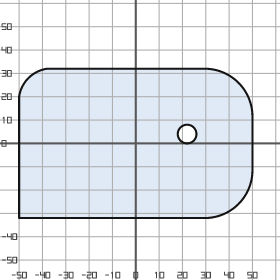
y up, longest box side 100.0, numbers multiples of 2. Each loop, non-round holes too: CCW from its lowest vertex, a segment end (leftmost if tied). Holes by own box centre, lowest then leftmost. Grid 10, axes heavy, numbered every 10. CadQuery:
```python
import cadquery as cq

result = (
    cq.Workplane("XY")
    .moveTo(-50.0, -32.0)
    .lineTo(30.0, -32.0)
    .threePointArc((44.0, -26.0), (50.0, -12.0))
    .lineTo(50.0, 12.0)
    .threePointArc((44.0, 26.0), (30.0, 32.0))
    .lineTo(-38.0, 32.0)
    .threePointArc((-46.0, 28.0), (-50.0, 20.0))
    .close()
    .moveTo(22.0, 4.0)
    .circle(4.0)
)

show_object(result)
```